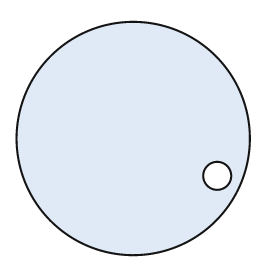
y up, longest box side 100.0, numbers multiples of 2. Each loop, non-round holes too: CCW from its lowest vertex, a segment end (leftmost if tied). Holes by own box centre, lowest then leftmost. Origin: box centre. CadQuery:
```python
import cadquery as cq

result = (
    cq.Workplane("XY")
    .moveTo(0.0, 0.0)
    .circle(50.0)
    .moveTo(36.0, -16.0)
    .circle(6.0)
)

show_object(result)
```